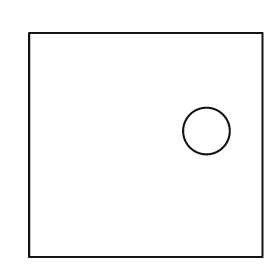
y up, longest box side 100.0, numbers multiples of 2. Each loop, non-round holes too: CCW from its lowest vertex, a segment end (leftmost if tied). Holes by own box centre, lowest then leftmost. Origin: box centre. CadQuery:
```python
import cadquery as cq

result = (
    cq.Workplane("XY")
    .moveTo(-50.0, -48.0)
    .lineTo(50.0, -48.0)
    .lineTo(50.0, 48.0)
    .lineTo(-50.0, 48.0)
    .close()
    .moveTo(26.0, 6.0)
    .circle(10.0)
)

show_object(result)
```